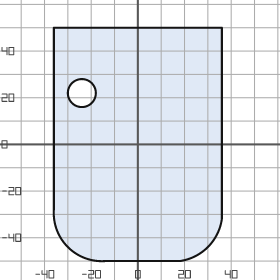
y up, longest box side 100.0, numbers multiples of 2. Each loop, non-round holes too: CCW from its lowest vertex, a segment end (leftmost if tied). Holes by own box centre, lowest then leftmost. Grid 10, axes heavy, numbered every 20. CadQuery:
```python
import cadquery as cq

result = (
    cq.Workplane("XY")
    .moveTo(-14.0, -50.0)
    .lineTo(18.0, -50.0)
    .threePointArc((30.0, -44.0), (36.0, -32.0))
    .lineTo(36.0, 50.0)
    .lineTo(-36.0, 50.0)
    .lineTo(-36.0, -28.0)
    .threePointArc((-30.0, -44.0), (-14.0, -50.0))
    .close()
    .moveTo(-24.0, 22.0)
    .circle(6.0)
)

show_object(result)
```